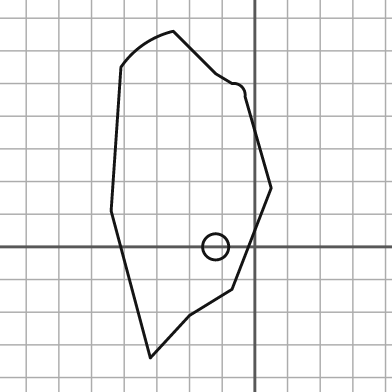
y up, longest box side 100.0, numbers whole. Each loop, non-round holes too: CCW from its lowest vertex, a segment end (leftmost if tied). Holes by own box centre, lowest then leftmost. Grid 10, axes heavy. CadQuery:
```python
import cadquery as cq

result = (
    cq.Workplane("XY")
    .moveTo(-32.0, -34.0)
    .lineTo(-20.0, -21.0)
    .lineTo(-7.0, -13.0)
    .lineTo(5.0, 18.0)
    .lineTo(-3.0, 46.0)
    .threePointArc((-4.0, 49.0), (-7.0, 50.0))
    .lineTo(-12.0, 53.0)
    .lineTo(-25.0, 66.0)
    .threePointArc((-34.0, 62.0), (-41.0, 55.0))
    .lineTo(-44.0, 11.0)
    .close()
    .moveTo(-12.0, 0.0)
    .circle(4.0)
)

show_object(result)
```